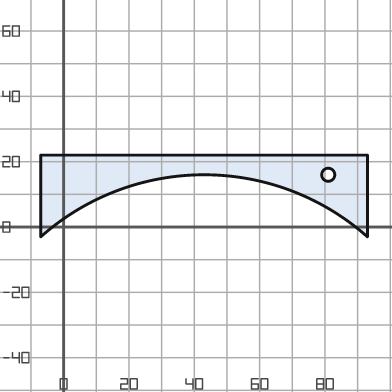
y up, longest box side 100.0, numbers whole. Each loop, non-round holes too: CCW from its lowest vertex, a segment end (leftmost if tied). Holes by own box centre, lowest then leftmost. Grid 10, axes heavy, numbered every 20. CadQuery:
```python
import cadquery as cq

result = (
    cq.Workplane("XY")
    .moveTo(-7.0, -3.0)
    .threePointArc((43.0, 16.0), (93.0, -3.0))
    .lineTo(93.0, 22.0)
    .lineTo(-7.0, 22.0)
    .close()
    .moveTo(81.0, 16.0)
    .circle(2.0)
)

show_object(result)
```